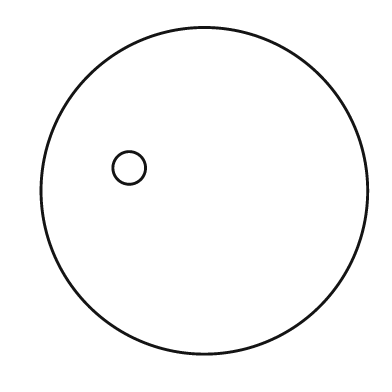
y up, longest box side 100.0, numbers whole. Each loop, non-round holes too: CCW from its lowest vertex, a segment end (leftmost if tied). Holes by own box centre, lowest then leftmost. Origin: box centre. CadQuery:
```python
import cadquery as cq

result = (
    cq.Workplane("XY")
    .moveTo(0.0, 0.0)
    .circle(50.0)
    .moveTo(-23.0, 7.0)
    .circle(5.0)
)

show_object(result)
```